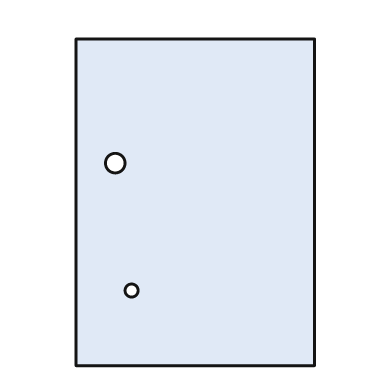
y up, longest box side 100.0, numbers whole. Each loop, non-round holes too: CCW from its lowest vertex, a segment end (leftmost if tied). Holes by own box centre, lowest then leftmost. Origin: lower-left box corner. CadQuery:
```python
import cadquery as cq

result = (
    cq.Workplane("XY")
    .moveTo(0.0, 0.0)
    .lineTo(73.0, 0.0)
    .lineTo(73.0, 100.0)
    .lineTo(0.0, 100.0)
    .close()
    .moveTo(17.0, 23.0)
    .circle(2.0)
    .moveTo(12.0, 62.0)
    .circle(3.0)
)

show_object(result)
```